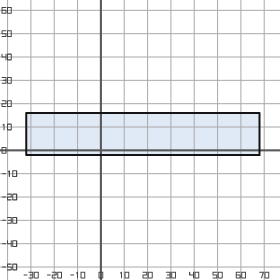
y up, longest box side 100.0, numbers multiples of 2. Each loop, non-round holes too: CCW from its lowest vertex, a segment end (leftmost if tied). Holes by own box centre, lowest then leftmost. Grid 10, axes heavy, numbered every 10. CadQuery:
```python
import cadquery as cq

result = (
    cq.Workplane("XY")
    .moveTo(-32.0, -2.0)
    .lineTo(68.0, -2.0)
    .lineTo(68.0, 16.0)
    .lineTo(-32.0, 16.0)
    .close()
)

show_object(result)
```